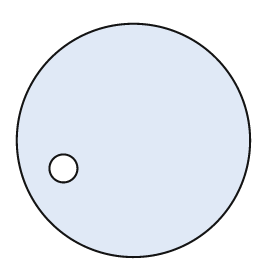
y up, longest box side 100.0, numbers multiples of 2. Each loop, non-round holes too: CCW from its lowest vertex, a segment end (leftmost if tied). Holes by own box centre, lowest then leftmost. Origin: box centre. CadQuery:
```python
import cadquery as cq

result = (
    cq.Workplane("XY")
    .moveTo(0.0, 0.0)
    .circle(50.0)
    .moveTo(-30.0, -12.0)
    .circle(6.0)
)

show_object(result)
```